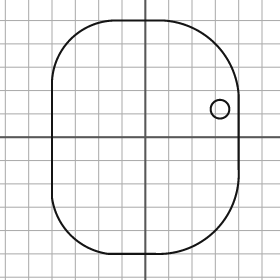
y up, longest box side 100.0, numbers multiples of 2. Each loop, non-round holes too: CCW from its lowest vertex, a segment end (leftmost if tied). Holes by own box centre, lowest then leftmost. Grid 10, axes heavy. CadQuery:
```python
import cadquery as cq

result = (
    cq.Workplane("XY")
    .moveTo(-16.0, -50.0)
    .lineTo(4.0, -50.0)
    .threePointArc((30.0, -40.0), (40.0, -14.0))
    .lineTo(40.0, 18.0)
    .threePointArc((30.0, 40.0), (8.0, 50.0))
    .lineTo(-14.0, 50.0)
    .threePointArc((-32.0, 42.0), (-40.0, 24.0))
    .lineTo(-40.0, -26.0)
    .threePointArc((-32.0, -42.0), (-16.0, -50.0))
    .close()
    .moveTo(32.0, 12.0)
    .circle(4.0)
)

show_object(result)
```